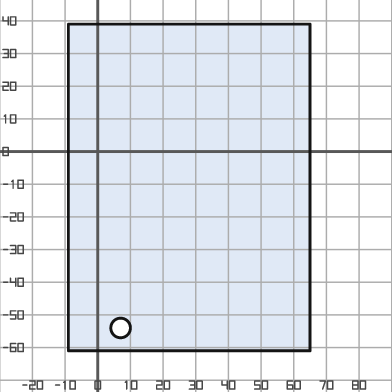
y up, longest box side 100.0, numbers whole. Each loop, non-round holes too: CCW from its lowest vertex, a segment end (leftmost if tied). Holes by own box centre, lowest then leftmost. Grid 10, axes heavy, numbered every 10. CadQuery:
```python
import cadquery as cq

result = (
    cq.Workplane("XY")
    .moveTo(-9.0, -61.0)
    .lineTo(65.0, -61.0)
    .lineTo(65.0, 39.0)
    .lineTo(-9.0, 39.0)
    .close()
    .moveTo(7.0, -54.0)
    .circle(3.0)
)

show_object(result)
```